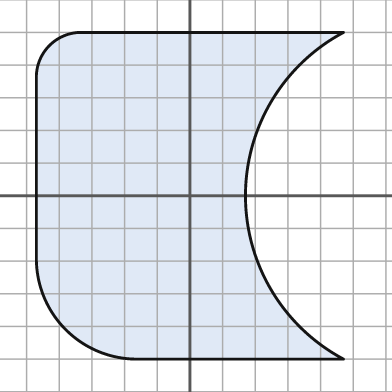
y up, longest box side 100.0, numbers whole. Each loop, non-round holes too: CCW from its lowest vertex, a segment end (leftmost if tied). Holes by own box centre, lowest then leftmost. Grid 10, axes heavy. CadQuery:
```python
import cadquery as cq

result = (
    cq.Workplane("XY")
    .moveTo(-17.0, -50.0)
    .lineTo(47.0, -50.0)
    .threePointArc((17.0, 0.0), (47.0, 50.0))
    .lineTo(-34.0, 50.0)
    .threePointArc((-43.0, 46.0), (-47.0, 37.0))
    .lineTo(-47.0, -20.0)
    .threePointArc((-38.0, -41.0), (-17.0, -50.0))
    .close()
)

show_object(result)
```